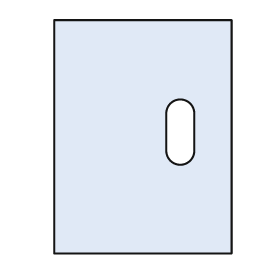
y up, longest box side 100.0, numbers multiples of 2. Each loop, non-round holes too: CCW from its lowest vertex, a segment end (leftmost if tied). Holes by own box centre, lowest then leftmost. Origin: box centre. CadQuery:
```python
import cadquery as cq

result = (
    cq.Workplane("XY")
    .moveTo(-38.0, -50.0)
    .lineTo(38.0, -50.0)
    .lineTo(38.0, 50.0)
    .lineTo(-38.0, 50.0)
    .close()
    .moveTo(10.0, -6.0)
    .threePointArc((16.0, -12.0), (22.0, -6.0))
    .lineTo(22.0, 10.0)
    .threePointArc((16.0, 16.0), (10.0, 10.0))
    .close()
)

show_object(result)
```